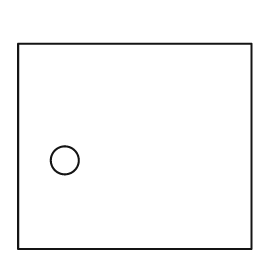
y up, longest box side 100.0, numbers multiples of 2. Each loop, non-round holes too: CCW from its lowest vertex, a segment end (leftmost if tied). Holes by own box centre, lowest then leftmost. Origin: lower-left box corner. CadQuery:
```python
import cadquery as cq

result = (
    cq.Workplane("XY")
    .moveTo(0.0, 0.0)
    .lineTo(100.0, 0.0)
    .lineTo(100.0, 88.0)
    .lineTo(0.0, 88.0)
    .close()
    .moveTo(20.0, 38.0)
    .circle(6.0)
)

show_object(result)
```